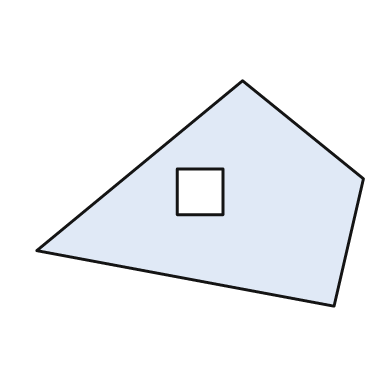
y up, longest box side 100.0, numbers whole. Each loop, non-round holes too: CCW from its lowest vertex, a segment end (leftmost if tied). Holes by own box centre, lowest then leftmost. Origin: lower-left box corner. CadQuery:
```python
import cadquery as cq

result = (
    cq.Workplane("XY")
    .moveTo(91.0, 0.0)
    .lineTo(100.0, 39.0)
    .lineTo(63.0, 69.0)
    .lineTo(0.0, 17.0)
    .close()
    .moveTo(43.0, 28.0)
    .lineTo(57.0, 28.0)
    .lineTo(57.0, 42.0)
    .lineTo(43.0, 42.0)
    .close()
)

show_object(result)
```